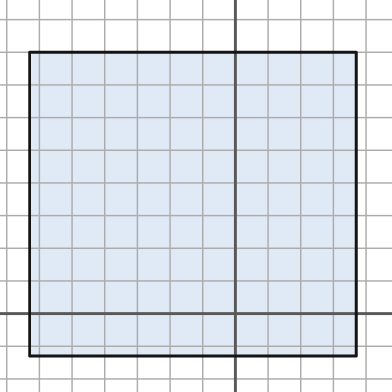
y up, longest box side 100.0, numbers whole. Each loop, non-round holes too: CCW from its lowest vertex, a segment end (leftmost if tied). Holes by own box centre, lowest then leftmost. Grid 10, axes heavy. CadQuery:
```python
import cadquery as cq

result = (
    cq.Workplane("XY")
    .moveTo(-63.0, -13.0)
    .lineTo(37.0, -13.0)
    .lineTo(37.0, 80.0)
    .lineTo(-63.0, 80.0)
    .close()
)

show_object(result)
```